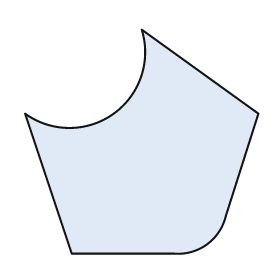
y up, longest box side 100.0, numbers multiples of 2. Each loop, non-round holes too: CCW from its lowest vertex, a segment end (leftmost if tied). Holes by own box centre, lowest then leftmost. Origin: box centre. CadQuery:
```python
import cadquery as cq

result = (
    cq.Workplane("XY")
    .moveTo(-30.0, -48.0)
    .lineTo(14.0, -48.0)
    .threePointArc((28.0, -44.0), (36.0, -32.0))
    .lineTo(50.0, 12.0)
    .lineTo(0.0, 48.0)
    .threePointArc((-12.0, 12.0), (-50.0, 12.0))
    .close()
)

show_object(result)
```